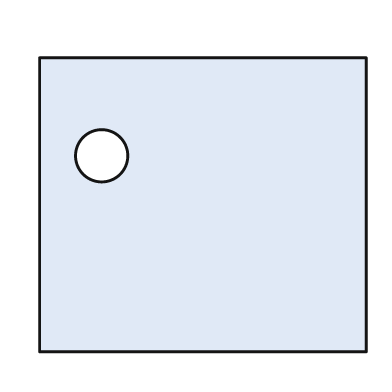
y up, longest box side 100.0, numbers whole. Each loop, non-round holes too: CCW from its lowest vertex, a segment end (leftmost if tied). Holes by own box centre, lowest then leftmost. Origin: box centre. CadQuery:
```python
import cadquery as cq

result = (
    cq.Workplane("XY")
    .moveTo(-50.0, -45.0)
    .lineTo(50.0, -45.0)
    .lineTo(50.0, 45.0)
    .lineTo(-50.0, 45.0)
    .close()
    .moveTo(-31.0, 15.0)
    .circle(8.0)
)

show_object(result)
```